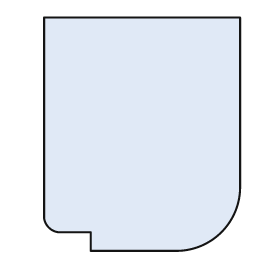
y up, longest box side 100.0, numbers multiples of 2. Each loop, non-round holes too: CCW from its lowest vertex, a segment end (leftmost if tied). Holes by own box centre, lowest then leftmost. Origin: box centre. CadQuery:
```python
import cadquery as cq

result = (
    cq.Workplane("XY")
    .moveTo(-22.0, -50.0)
    .lineTo(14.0, -50.0)
    .threePointArc((34.0, -42.0), (42.0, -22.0))
    .lineTo(42.0, 50.0)
    .lineTo(-42.0, 50.0)
    .lineTo(-42.0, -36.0)
    .threePointArc((-40.0, -40.0), (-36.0, -42.0))
    .lineTo(-22.0, -42.0)
    .close()
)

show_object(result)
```